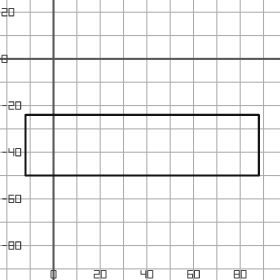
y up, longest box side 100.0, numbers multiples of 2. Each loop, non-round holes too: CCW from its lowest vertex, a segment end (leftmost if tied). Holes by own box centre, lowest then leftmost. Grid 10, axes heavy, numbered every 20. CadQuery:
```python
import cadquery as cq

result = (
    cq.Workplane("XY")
    .moveTo(-12.0, -50.0)
    .lineTo(88.0, -50.0)
    .lineTo(88.0, -24.0)
    .lineTo(-12.0, -24.0)
    .close()
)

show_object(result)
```